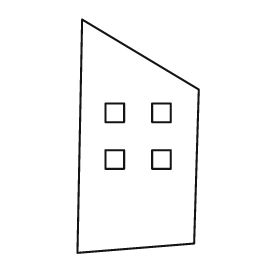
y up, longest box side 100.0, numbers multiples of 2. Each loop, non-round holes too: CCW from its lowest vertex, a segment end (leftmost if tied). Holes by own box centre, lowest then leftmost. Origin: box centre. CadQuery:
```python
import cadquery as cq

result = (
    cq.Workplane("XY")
    .moveTo(-26.0, -50.0)
    .lineTo(24.0, -46.0)
    .lineTo(26.0, 20.0)
    .lineTo(-24.0, 50.0)
    .close()
    .moveTo(-14.0, -14.0)
    .lineTo(-6.0, -14.0)
    .lineTo(-6.0, -6.0)
    .lineTo(-14.0, -6.0)
    .close()
    .moveTo(6.0, -14.0)
    .lineTo(14.0, -14.0)
    .lineTo(14.0, -6.0)
    .lineTo(6.0, -6.0)
    .close()
    .moveTo(-14.0, 6.0)
    .lineTo(-6.0, 6.0)
    .lineTo(-6.0, 14.0)
    .lineTo(-14.0, 14.0)
    .close()
    .moveTo(6.0, 6.0)
    .lineTo(14.0, 6.0)
    .lineTo(14.0, 14.0)
    .lineTo(6.0, 14.0)
    .close()
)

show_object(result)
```